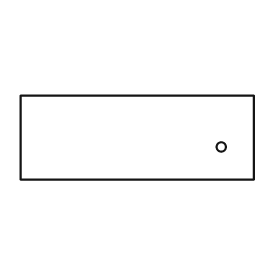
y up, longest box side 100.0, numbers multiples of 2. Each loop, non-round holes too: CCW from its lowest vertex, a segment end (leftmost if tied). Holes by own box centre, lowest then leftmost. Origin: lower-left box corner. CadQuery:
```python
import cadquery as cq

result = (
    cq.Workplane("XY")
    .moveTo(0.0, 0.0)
    .lineTo(100.0, 0.0)
    .lineTo(100.0, 36.0)
    .lineTo(0.0, 36.0)
    .close()
    .moveTo(86.0, 14.0)
    .circle(2.0)
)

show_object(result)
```